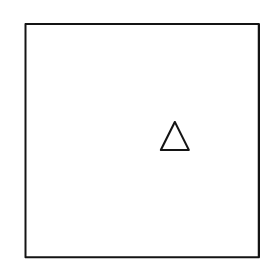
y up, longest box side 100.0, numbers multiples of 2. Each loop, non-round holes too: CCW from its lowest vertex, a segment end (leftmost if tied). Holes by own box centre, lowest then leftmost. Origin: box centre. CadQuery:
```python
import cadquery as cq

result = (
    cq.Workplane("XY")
    .moveTo(-50.0, -50.0)
    .lineTo(50.0, -50.0)
    .lineTo(50.0, 50.0)
    .lineTo(-50.0, 50.0)
    .close()
    .moveTo(8.0, -4.0)
    .lineTo(20.0, -4.0)
    .lineTo(14.0, 8.0)
    .close()
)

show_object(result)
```